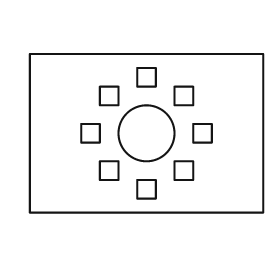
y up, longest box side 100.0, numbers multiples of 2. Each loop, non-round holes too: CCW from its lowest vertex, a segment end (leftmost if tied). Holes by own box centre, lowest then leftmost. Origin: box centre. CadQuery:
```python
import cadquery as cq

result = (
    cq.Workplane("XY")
    .moveTo(-50.0, -34.0)
    .lineTo(50.0, -34.0)
    .lineTo(50.0, 34.0)
    .lineTo(-50.0, 34.0)
    .close()
    .moveTo(-4.0, -28.0)
    .lineTo(4.0, -28.0)
    .lineTo(4.0, -20.0)
    .lineTo(-4.0, -20.0)
    .close()
    .moveTo(-20.0, -20.0)
    .lineTo(-12.0, -20.0)
    .lineTo(-12.0, -12.0)
    .lineTo(-20.0, -12.0)
    .close()
    .moveTo(12.0, -20.0)
    .lineTo(20.0, -20.0)
    .lineTo(20.0, -12.0)
    .lineTo(12.0, -12.0)
    .close()
    .moveTo(-28.0, -4.0)
    .lineTo(-20.0, -4.0)
    .lineTo(-20.0, 4.0)
    .lineTo(-28.0, 4.0)
    .close()
    .moveTo(0.0, 0.0)
    .circle(12.0)
    .moveTo(20.0, -4.0)
    .lineTo(28.0, -4.0)
    .lineTo(28.0, 4.0)
    .lineTo(20.0, 4.0)
    .close()
    .moveTo(-20.0, 12.0)
    .lineTo(-12.0, 12.0)
    .lineTo(-12.0, 20.0)
    .lineTo(-20.0, 20.0)
    .close()
    .moveTo(12.0, 12.0)
    .lineTo(20.0, 12.0)
    .lineTo(20.0, 20.0)
    .lineTo(12.0, 20.0)
    .close()
    .moveTo(-4.0, 20.0)
    .lineTo(4.0, 20.0)
    .lineTo(4.0, 28.0)
    .lineTo(-4.0, 28.0)
    .close()
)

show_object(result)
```